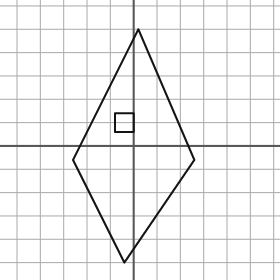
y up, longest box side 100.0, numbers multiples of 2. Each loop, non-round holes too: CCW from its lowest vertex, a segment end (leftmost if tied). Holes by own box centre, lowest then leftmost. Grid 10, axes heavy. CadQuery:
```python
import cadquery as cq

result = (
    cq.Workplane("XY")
    .moveTo(-4.0, -50.0)
    .lineTo(26.0, -6.0)
    .lineTo(2.0, 50.0)
    .lineTo(-26.0, -6.0)
    .close()
    .moveTo(-8.0, 6.0)
    .lineTo(0.0, 6.0)
    .lineTo(0.0, 14.0)
    .lineTo(-8.0, 14.0)
    .close()
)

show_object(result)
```